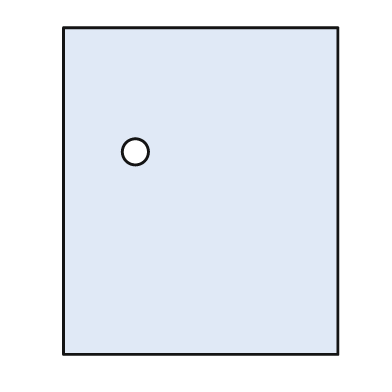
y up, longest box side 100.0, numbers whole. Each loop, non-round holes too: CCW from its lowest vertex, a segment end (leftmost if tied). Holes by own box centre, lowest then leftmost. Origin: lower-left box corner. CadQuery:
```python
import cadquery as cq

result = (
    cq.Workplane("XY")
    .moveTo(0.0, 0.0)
    .lineTo(84.0, 0.0)
    .lineTo(84.0, 100.0)
    .lineTo(0.0, 100.0)
    .close()
    .moveTo(22.0, 62.0)
    .circle(4.0)
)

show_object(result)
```